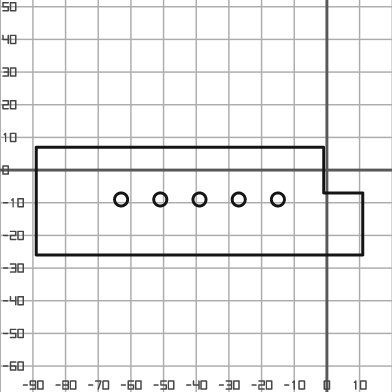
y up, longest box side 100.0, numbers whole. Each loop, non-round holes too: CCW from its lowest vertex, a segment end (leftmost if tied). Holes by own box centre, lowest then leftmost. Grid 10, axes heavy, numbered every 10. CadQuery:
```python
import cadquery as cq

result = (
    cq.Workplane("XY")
    .moveTo(-89.0, -26.0)
    .lineTo(11.0, -26.0)
    .lineTo(11.0, -7.0)
    .lineTo(-1.0, -7.0)
    .lineTo(-1.0, 7.0)
    .lineTo(-89.0, 7.0)
    .close()
    .moveTo(-63.0, -9.0)
    .circle(2.0)
    .moveTo(-51.0, -9.0)
    .circle(2.0)
    .moveTo(-39.0, -9.0)
    .circle(2.0)
    .moveTo(-27.0, -9.0)
    .circle(2.0)
    .moveTo(-15.0, -9.0)
    .circle(2.0)
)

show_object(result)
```